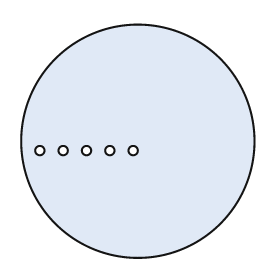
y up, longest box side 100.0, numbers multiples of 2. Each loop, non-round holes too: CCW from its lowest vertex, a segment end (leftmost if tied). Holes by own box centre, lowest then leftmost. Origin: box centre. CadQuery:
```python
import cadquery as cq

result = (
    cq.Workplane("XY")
    .moveTo(0.0, 0.0)
    .circle(50.0)
    .moveTo(-42.0, -4.0)
    .circle(2.0)
    .moveTo(-32.0, -4.0)
    .circle(2.0)
    .moveTo(-22.0, -4.0)
    .circle(2.0)
    .moveTo(-12.0, -4.0)
    .circle(2.0)
    .moveTo(-2.0, -4.0)
    .circle(2.0)
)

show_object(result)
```